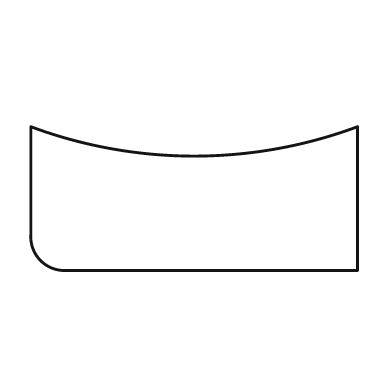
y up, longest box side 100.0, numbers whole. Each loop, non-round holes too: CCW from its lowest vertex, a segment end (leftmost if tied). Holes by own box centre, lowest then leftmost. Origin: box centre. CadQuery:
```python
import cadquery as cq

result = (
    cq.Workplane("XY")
    .moveTo(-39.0, -22.0)
    .lineTo(50.0, -22.0)
    .lineTo(50.0, 22.0)
    .threePointArc((0.0, 13.0), (-50.0, 22.0))
    .lineTo(-50.0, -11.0)
    .threePointArc((-47.0, -19.0), (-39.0, -22.0))
    .close()
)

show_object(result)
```